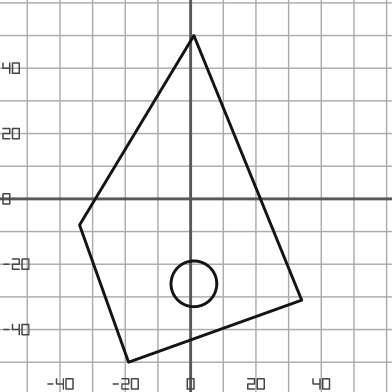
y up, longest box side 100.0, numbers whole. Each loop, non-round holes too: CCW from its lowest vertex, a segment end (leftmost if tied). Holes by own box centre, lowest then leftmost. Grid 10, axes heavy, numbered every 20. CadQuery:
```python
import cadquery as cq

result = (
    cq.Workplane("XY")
    .moveTo(-19.0, -50.0)
    .lineTo(34.0, -31.0)
    .lineTo(1.0, 50.0)
    .lineTo(-34.0, -8.0)
    .close()
    .moveTo(1.0, -26.0)
    .circle(7.0)
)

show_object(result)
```